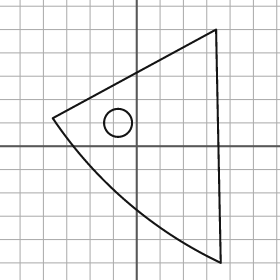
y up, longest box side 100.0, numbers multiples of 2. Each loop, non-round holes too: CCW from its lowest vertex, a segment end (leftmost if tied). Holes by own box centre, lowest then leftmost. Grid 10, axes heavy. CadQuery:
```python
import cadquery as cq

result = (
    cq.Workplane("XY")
    .moveTo(36.0, -50.0)
    .lineTo(34.0, 50.0)
    .lineTo(-36.0, 12.0)
    .threePointArc((-4.0, -24.0), (36.0, -50.0))
    .close()
    .moveTo(-8.0, 10.0)
    .circle(6.0)
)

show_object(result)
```